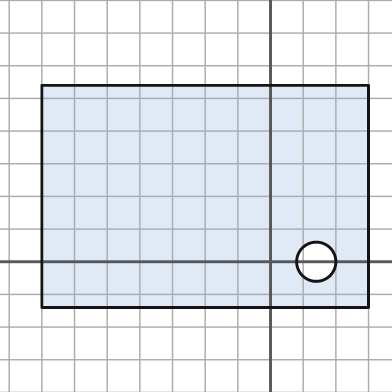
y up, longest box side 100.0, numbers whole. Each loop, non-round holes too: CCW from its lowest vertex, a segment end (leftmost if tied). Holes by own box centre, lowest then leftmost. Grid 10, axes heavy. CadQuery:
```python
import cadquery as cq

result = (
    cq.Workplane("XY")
    .moveTo(-70.0, -14.0)
    .lineTo(30.0, -14.0)
    .lineTo(30.0, 54.0)
    .lineTo(-70.0, 54.0)
    .close()
    .moveTo(14.0, 0.0)
    .circle(6.0)
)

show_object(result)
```